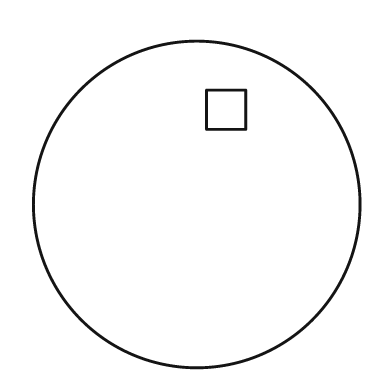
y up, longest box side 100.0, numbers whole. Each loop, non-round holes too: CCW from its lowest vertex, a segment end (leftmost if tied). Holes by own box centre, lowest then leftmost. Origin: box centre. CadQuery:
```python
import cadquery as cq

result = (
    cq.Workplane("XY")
    .moveTo(0.0, 0.0)
    .circle(50.0)
    .moveTo(3.0, 23.0)
    .lineTo(15.0, 23.0)
    .lineTo(15.0, 35.0)
    .lineTo(3.0, 35.0)
    .close()
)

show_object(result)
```